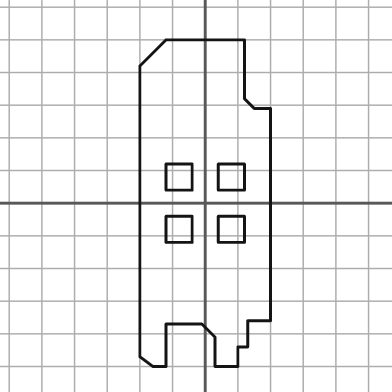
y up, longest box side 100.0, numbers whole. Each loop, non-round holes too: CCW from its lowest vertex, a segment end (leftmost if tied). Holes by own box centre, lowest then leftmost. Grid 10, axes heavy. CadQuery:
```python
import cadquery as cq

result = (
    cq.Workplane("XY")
    .moveTo(-16.0, -50.0)
    .lineTo(-12.0, -50.0)
    .lineTo(-12.0, -37.0)
    .lineTo(-1.0, -37.0)
    .lineTo(3.0, -41.0)
    .lineTo(3.0, -50.0)
    .lineTo(10.0, -50.0)
    .lineTo(10.0, -44.0)
    .lineTo(13.0, -44.0)
    .lineTo(13.0, -36.0)
    .lineTo(20.0, -36.0)
    .lineTo(20.0, 29.0)
    .lineTo(15.0, 29.0)
    .lineTo(12.0, 32.0)
    .lineTo(12.0, 50.0)
    .lineTo(-12.0, 50.0)
    .lineTo(-20.0, 42.0)
    .lineTo(-20.0, -47.0)
    .close()
    .moveTo(-12.0, -12.0)
    .lineTo(-4.0, -12.0)
    .lineTo(-4.0, -4.0)
    .lineTo(-12.0, -4.0)
    .close()
    .moveTo(4.0, -12.0)
    .lineTo(12.0, -12.0)
    .lineTo(12.0, -4.0)
    .lineTo(4.0, -4.0)
    .close()
    .moveTo(-12.0, 4.0)
    .lineTo(-4.0, 4.0)
    .lineTo(-4.0, 12.0)
    .lineTo(-12.0, 12.0)
    .close()
    .moveTo(4.0, 4.0)
    .lineTo(12.0, 4.0)
    .lineTo(12.0, 12.0)
    .lineTo(4.0, 12.0)
    .close()
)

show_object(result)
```